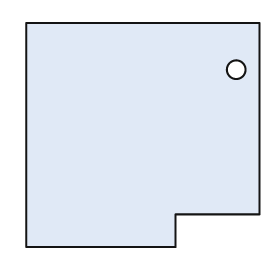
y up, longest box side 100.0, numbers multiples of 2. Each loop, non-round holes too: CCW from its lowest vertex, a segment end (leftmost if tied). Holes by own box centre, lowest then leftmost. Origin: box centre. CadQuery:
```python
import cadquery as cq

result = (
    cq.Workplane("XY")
    .moveTo(-50.0, -48.0)
    .lineTo(14.0, -48.0)
    .lineTo(14.0, -34.0)
    .lineTo(50.0, -34.0)
    .lineTo(50.0, 48.0)
    .lineTo(-50.0, 48.0)
    .close()
    .moveTo(40.0, 28.0)
    .circle(4.0)
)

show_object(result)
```